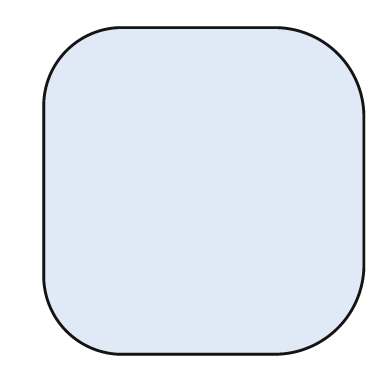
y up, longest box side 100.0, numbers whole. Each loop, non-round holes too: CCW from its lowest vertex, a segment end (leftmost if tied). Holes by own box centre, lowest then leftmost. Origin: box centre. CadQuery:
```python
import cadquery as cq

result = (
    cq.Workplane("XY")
    .moveTo(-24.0, -50.0)
    .lineTo(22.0, -50.0)
    .threePointArc((41.0, -42.0), (49.0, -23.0))
    .lineTo(49.0, 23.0)
    .threePointArc((41.0, 42.0), (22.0, 50.0))
    .lineTo(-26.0, 50.0)
    .threePointArc((-42.0, 43.0), (-49.0, 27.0))
    .lineTo(-49.0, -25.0)
    .threePointArc((-42.0, -43.0), (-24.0, -50.0))
    .close()
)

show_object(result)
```